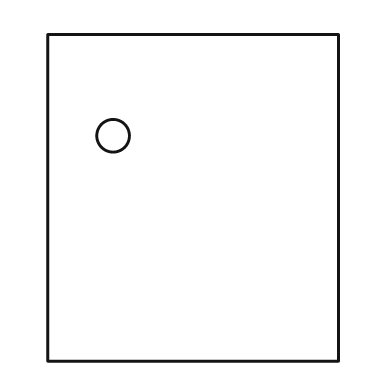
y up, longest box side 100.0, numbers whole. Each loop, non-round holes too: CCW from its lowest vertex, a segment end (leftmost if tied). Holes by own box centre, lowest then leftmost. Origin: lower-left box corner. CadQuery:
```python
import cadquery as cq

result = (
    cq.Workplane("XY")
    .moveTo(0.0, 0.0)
    .lineTo(89.0, 0.0)
    .lineTo(89.0, 100.0)
    .lineTo(0.0, 100.0)
    .close()
    .moveTo(20.0, 69.0)
    .circle(5.0)
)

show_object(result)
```